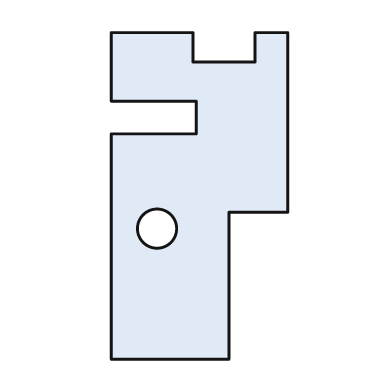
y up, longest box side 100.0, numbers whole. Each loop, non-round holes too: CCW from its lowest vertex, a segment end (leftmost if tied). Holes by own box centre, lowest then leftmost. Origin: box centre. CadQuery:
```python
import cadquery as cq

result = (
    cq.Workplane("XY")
    .moveTo(-27.0, -50.0)
    .lineTo(9.0, -50.0)
    .lineTo(9.0, -5.0)
    .lineTo(27.0, -5.0)
    .lineTo(27.0, 50.0)
    .lineTo(17.0, 50.0)
    .lineTo(17.0, 41.0)
    .lineTo(-2.0, 41.0)
    .lineTo(-2.0, 50.0)
    .lineTo(-27.0, 50.0)
    .lineTo(-27.0, 29.0)
    .lineTo(-1.0, 29.0)
    .lineTo(-1.0, 19.0)
    .lineTo(-27.0, 19.0)
    .close()
    .moveTo(-13.0, -10.0)
    .circle(6.0)
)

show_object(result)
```